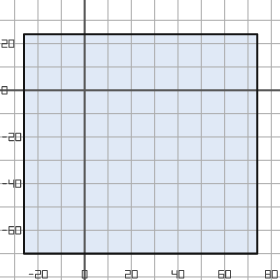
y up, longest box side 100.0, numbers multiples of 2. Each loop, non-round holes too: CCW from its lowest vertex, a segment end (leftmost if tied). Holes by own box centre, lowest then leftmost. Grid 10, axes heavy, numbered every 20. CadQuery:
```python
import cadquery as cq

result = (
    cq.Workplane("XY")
    .moveTo(-26.0, -70.0)
    .lineTo(74.0, -70.0)
    .lineTo(74.0, 24.0)
    .lineTo(-26.0, 24.0)
    .close()
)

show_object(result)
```